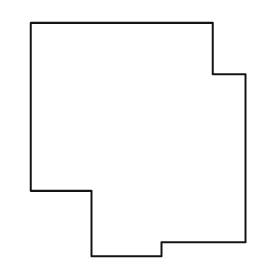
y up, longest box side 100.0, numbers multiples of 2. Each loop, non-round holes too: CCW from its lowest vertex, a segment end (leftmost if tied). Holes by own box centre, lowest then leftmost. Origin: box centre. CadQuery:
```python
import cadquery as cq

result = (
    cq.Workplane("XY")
    .moveTo(-20.0, -50.0)
    .lineTo(10.0, -50.0)
    .lineTo(10.0, -44.0)
    .lineTo(46.0, -44.0)
    .lineTo(46.0, 28.0)
    .lineTo(32.0, 28.0)
    .lineTo(32.0, 50.0)
    .lineTo(-46.0, 50.0)
    .lineTo(-46.0, -22.0)
    .lineTo(-20.0, -22.0)
    .close()
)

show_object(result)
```